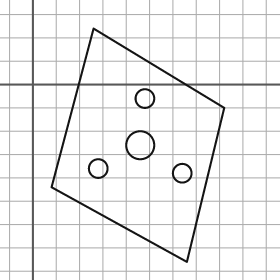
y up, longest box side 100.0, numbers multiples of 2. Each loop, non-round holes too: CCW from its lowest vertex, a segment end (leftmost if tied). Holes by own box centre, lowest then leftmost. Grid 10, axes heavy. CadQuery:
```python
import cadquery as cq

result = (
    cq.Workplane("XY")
    .moveTo(66.0, -76.0)
    .lineTo(82.0, -10.0)
    .lineTo(26.0, 24.0)
    .lineTo(8.0, -44.0)
    .close()
    .moveTo(64.0, -38.0)
    .circle(4.0)
    .moveTo(28.0, -36.0)
    .circle(4.0)
    .moveTo(46.0, -26.0)
    .circle(6.0)
    .moveTo(48.0, -6.0)
    .circle(4.0)
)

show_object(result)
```